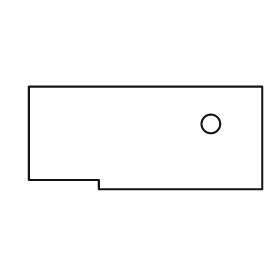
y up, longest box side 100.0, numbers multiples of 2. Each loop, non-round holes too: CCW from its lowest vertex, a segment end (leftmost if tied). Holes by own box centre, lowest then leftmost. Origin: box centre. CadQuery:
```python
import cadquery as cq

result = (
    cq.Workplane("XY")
    .moveTo(-20.0, -22.0)
    .lineTo(50.0, -22.0)
    .lineTo(50.0, 22.0)
    .lineTo(-50.0, 22.0)
    .lineTo(-50.0, -18.0)
    .lineTo(-20.0, -18.0)
    .close()
    .moveTo(28.0, 6.0)
    .circle(4.0)
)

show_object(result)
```